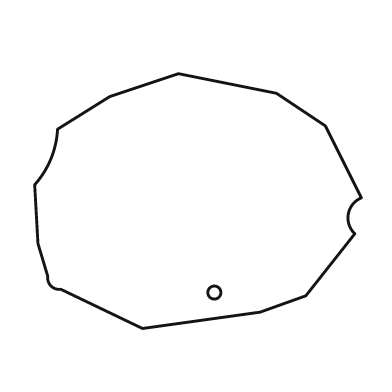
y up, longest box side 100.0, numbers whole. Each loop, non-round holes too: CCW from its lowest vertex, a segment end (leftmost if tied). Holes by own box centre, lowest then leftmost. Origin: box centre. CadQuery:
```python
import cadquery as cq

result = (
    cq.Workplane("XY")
    .moveTo(-17.0, -39.0)
    .lineTo(19.0, -34.0)
    .lineTo(33.0, -29.0)
    .lineTo(48.0, -10.0)
    .threePointArc((46.0, -4.0), (50.0, 1.0))
    .lineTo(39.0, 23.0)
    .lineTo(24.0, 33.0)
    .lineTo(-6.0, 39.0)
    .lineTo(-27.0, 32.0)
    .lineTo(-43.0, 22.0)
    .threePointArc((-45.0, 13.0), (-50.0, 5.0))
    .lineTo(-49.0, -13.0)
    .lineTo(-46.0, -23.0)
    .threePointArc((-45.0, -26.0), (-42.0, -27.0))
    .close()
    .moveTo(5.0, -28.0)
    .circle(2.0)
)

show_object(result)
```